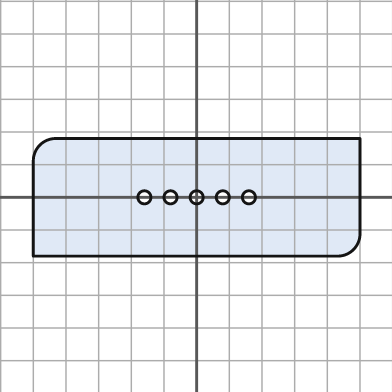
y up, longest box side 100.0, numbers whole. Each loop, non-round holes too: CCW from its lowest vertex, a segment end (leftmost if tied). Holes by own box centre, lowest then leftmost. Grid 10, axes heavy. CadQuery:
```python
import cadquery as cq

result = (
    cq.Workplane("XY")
    .moveTo(-50.0, -18.0)
    .lineTo(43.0, -18.0)
    .threePointArc((48.0, -16.0), (50.0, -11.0))
    .lineTo(50.0, 18.0)
    .lineTo(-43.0, 18.0)
    .threePointArc((-48.0, 16.0), (-50.0, 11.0))
    .close()
    .moveTo(-16.0, 0.0)
    .circle(2.0)
    .moveTo(-8.0, 0.0)
    .circle(2.0)
    .moveTo(0.0, 0.0)
    .circle(2.0)
    .moveTo(8.0, 0.0)
    .circle(2.0)
    .moveTo(16.0, 0.0)
    .circle(2.0)
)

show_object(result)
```